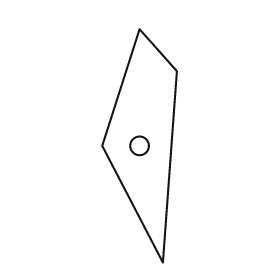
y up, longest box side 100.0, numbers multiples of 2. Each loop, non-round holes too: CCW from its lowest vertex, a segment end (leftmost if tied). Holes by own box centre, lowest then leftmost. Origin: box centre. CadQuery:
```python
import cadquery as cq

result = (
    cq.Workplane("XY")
    .moveTo(10.0, -50.0)
    .lineTo(16.0, 32.0)
    .lineTo(0.0, 50.0)
    .lineTo(-16.0, 0.0)
    .close()
    .moveTo(0.0, 0.0)
    .circle(4.0)
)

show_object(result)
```